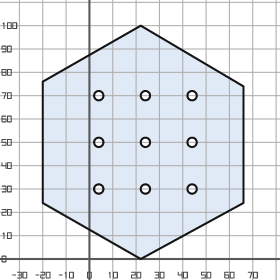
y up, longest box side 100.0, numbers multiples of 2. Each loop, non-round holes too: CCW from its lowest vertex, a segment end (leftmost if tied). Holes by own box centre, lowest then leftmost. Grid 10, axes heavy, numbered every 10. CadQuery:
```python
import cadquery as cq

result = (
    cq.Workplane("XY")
    .moveTo(22.0, 0.0)
    .lineTo(66.0, 24.0)
    .lineTo(66.0, 74.0)
    .lineTo(22.0, 100.0)
    .lineTo(-20.0, 76.0)
    .lineTo(-20.0, 24.0)
    .close()
    .moveTo(4.0, 30.0)
    .circle(2.0)
    .moveTo(24.0, 30.0)
    .circle(2.0)
    .moveTo(44.0, 30.0)
    .circle(2.0)
    .moveTo(4.0, 50.0)
    .circle(2.0)
    .moveTo(24.0, 50.0)
    .circle(2.0)
    .moveTo(44.0, 50.0)
    .circle(2.0)
    .moveTo(4.0, 70.0)
    .circle(2.0)
    .moveTo(24.0, 70.0)
    .circle(2.0)
    .moveTo(44.0, 70.0)
    .circle(2.0)
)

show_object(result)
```